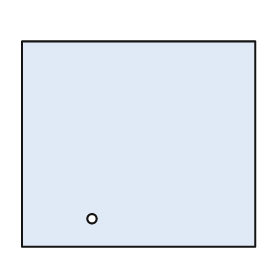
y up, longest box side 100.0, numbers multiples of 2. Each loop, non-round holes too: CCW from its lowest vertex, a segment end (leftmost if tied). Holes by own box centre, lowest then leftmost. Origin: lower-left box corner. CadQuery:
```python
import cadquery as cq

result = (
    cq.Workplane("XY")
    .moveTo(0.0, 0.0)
    .lineTo(100.0, 0.0)
    .lineTo(100.0, 88.0)
    .lineTo(0.0, 88.0)
    .close()
    .moveTo(30.0, 12.0)
    .circle(2.0)
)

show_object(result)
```